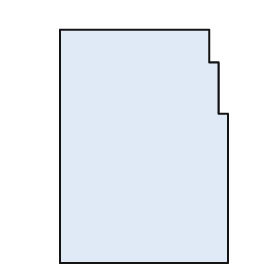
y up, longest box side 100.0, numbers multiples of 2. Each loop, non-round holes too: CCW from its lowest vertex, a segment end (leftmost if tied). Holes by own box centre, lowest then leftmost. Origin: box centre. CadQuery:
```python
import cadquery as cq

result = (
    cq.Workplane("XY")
    .moveTo(-36.0, -50.0)
    .lineTo(36.0, -50.0)
    .lineTo(36.0, 14.0)
    .lineTo(32.0, 14.0)
    .lineTo(32.0, 36.0)
    .lineTo(28.0, 36.0)
    .lineTo(28.0, 50.0)
    .lineTo(-36.0, 50.0)
    .close()
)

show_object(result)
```